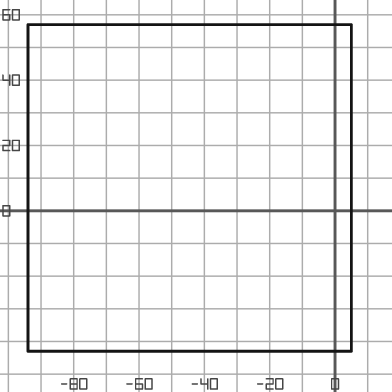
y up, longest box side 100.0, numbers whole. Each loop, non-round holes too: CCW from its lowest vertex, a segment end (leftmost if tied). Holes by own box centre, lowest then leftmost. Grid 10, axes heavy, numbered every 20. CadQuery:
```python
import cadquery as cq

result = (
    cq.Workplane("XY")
    .moveTo(-94.0, -43.0)
    .lineTo(5.0, -43.0)
    .lineTo(5.0, 57.0)
    .lineTo(-94.0, 57.0)
    .close()
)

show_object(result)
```